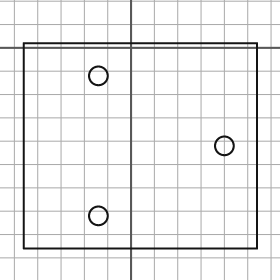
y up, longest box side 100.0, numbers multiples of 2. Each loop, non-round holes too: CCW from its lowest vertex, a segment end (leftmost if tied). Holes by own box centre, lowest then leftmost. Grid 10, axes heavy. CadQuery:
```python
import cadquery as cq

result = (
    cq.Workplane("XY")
    .moveTo(-46.0, -86.0)
    .lineTo(54.0, -86.0)
    .lineTo(54.0, 2.0)
    .lineTo(-46.0, 2.0)
    .close()
    .moveTo(-14.0, -72.0)
    .circle(4.0)
    .moveTo(40.0, -42.0)
    .circle(4.0)
    .moveTo(-14.0, -12.0)
    .circle(4.0)
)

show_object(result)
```